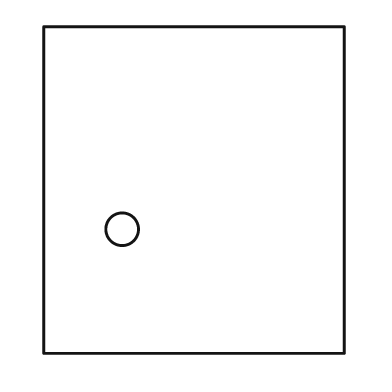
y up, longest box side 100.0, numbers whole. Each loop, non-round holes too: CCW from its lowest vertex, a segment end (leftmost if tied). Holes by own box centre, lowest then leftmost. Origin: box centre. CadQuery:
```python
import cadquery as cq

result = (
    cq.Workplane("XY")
    .moveTo(-46.0, -50.0)
    .lineTo(46.0, -50.0)
    .lineTo(46.0, 50.0)
    .lineTo(-46.0, 50.0)
    .close()
    .moveTo(-22.0, -12.0)
    .circle(5.0)
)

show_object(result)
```